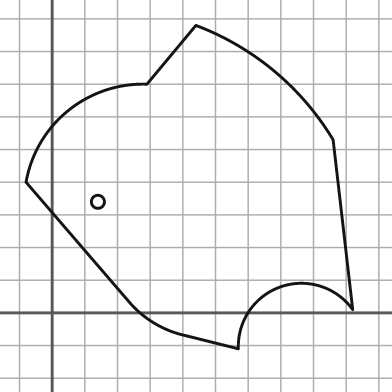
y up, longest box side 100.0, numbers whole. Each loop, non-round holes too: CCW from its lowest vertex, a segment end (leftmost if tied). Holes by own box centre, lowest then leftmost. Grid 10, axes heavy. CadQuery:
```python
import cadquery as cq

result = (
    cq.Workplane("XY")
    .moveTo(57.0, -11.0)
    .threePointArc((70.0, 8.0), (92.0, 1.0))
    .lineTo(86.0, 53.0)
    .threePointArc((68.0, 74.0), (44.0, 88.0))
    .lineTo(29.0, 70.0)
    .threePointArc((5.0, 62.0), (-8.0, 40.0))
    .lineTo(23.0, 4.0)
    .threePointArc((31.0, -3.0), (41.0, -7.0))
    .close()
    .moveTo(14.0, 34.0)
    .circle(2.0)
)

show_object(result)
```